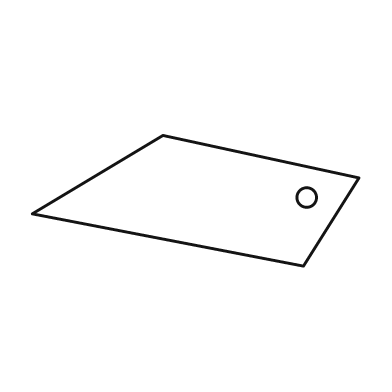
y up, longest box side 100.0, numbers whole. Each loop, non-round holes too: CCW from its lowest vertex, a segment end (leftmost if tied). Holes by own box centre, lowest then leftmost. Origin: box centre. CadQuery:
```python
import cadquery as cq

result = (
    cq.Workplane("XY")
    .moveTo(33.0, -20.0)
    .lineTo(50.0, 7.0)
    .lineTo(-10.0, 20.0)
    .lineTo(-50.0, -4.0)
    .close()
    .moveTo(34.0, 1.0)
    .circle(3.0)
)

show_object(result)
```